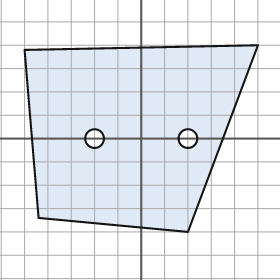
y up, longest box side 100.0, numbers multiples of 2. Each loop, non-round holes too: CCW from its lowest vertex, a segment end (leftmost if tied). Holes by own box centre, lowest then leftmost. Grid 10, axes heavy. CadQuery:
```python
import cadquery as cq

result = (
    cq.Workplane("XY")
    .moveTo(20.0, -40.0)
    .lineTo(50.0, 40.0)
    .lineTo(-50.0, 38.0)
    .lineTo(-44.0, -34.0)
    .close()
    .moveTo(-20.0, 0.0)
    .circle(4.0)
    .moveTo(20.0, 0.0)
    .circle(4.0)
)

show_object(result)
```